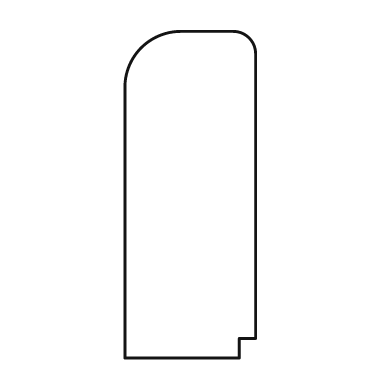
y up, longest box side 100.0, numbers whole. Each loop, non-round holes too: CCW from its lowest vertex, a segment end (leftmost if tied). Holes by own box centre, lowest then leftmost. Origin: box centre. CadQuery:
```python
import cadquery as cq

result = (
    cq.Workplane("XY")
    .moveTo(-20.0, -50.0)
    .lineTo(15.0, -50.0)
    .lineTo(15.0, -44.0)
    .lineTo(20.0, -44.0)
    .lineTo(20.0, 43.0)
    .threePointArc((18.0, 48.0), (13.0, 50.0))
    .lineTo(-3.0, 50.0)
    .threePointArc((-15.0, 45.0), (-20.0, 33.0))
    .close()
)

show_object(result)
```